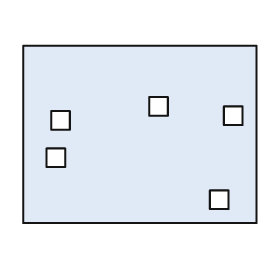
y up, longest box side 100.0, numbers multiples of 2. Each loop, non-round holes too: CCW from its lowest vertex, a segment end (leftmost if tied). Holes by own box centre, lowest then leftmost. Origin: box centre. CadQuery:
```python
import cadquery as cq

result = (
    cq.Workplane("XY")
    .moveTo(-50.0, -38.0)
    .lineTo(50.0, -38.0)
    .lineTo(50.0, 38.0)
    .lineTo(-50.0, 38.0)
    .close()
    .moveTo(30.0, -32.0)
    .lineTo(38.0, -32.0)
    .lineTo(38.0, -24.0)
    .lineTo(30.0, -24.0)
    .close()
    .moveTo(-40.0, -14.0)
    .lineTo(-32.0, -14.0)
    .lineTo(-32.0, -6.0)
    .lineTo(-40.0, -6.0)
    .close()
    .moveTo(-38.0, 2.0)
    .lineTo(-30.0, 2.0)
    .lineTo(-30.0, 10.0)
    .lineTo(-38.0, 10.0)
    .close()
    .moveTo(36.0, 4.0)
    .lineTo(44.0, 4.0)
    .lineTo(44.0, 12.0)
    .lineTo(36.0, 12.0)
    .close()
    .moveTo(4.0, 8.0)
    .lineTo(12.0, 8.0)
    .lineTo(12.0, 16.0)
    .lineTo(4.0, 16.0)
    .close()
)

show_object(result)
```